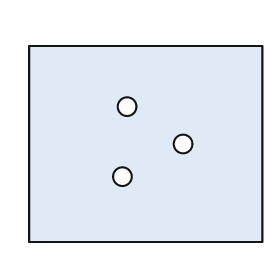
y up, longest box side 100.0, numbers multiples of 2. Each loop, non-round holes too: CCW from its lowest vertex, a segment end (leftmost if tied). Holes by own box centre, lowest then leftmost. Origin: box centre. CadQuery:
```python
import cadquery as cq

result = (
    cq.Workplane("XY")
    .moveTo(-50.0, -42.0)
    .lineTo(50.0, -42.0)
    .lineTo(50.0, 42.0)
    .lineTo(-50.0, 42.0)
    .close()
    .moveTo(-10.0, -14.0)
    .circle(4.0)
    .moveTo(16.0, 0.0)
    .circle(4.0)
    .moveTo(-8.0, 16.0)
    .circle(4.0)
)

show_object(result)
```